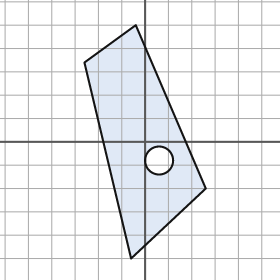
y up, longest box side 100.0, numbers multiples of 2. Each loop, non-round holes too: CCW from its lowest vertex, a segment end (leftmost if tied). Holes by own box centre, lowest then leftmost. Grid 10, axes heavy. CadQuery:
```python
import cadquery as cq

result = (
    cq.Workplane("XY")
    .moveTo(-6.0, -50.0)
    .lineTo(26.0, -20.0)
    .lineTo(-4.0, 50.0)
    .lineTo(-26.0, 34.0)
    .close()
    .moveTo(6.0, -8.0)
    .circle(6.0)
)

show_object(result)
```